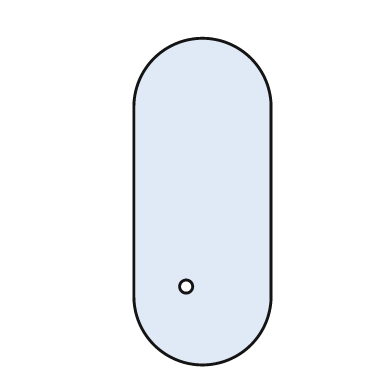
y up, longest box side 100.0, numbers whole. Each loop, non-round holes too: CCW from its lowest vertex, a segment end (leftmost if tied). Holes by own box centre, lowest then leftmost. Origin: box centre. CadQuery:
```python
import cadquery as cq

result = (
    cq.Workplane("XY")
    .moveTo(-21.0, -29.0)
    .threePointArc((0.0, -50.0), (21.0, -29.0))
    .lineTo(21.0, 29.0)
    .threePointArc((0.0, 50.0), (-21.0, 29.0))
    .close()
    .moveTo(-5.0, -26.0)
    .circle(2.0)
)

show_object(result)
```